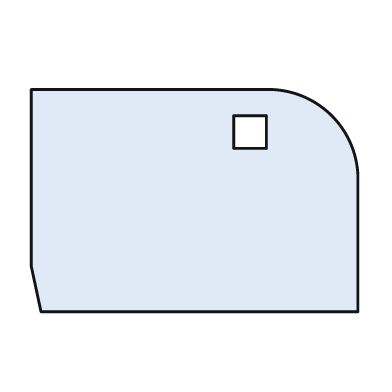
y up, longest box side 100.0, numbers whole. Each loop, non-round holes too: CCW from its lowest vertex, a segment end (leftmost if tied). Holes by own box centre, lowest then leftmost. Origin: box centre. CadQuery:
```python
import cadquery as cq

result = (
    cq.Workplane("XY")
    .moveTo(-47.0, -34.0)
    .lineTo(50.0, -34.0)
    .lineTo(50.0, 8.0)
    .threePointArc((42.0, 26.0), (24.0, 34.0))
    .lineTo(-50.0, 34.0)
    .lineTo(-50.0, -20.0)
    .close()
    .moveTo(12.0, 16.0)
    .lineTo(22.0, 16.0)
    .lineTo(22.0, 26.0)
    .lineTo(12.0, 26.0)
    .close()
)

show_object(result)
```